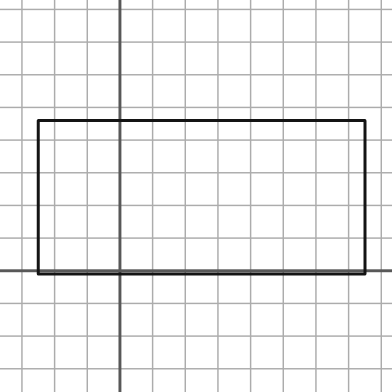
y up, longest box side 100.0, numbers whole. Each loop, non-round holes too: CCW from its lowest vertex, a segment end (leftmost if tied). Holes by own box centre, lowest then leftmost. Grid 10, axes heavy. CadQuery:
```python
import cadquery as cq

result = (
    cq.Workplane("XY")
    .moveTo(-25.0, -1.0)
    .lineTo(75.0, -1.0)
    .lineTo(75.0, 46.0)
    .lineTo(-25.0, 46.0)
    .close()
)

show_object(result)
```